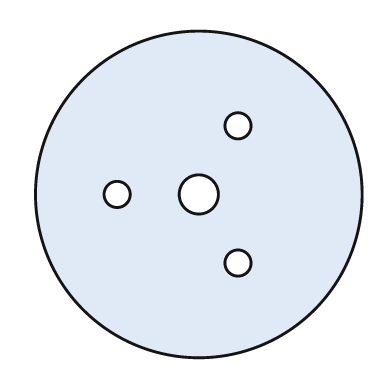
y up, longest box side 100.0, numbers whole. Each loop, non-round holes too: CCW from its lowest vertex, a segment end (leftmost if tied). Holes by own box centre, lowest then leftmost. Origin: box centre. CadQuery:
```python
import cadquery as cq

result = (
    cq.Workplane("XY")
    .moveTo(0.0, 0.0)
    .circle(50.0)
    .moveTo(12.0, -21.0)
    .circle(4.0)
    .moveTo(-25.0, 0.0)
    .circle(4.0)
    .moveTo(0.0, 0.0)
    .circle(6.0)
    .moveTo(12.0, 21.0)
    .circle(4.0)
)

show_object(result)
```